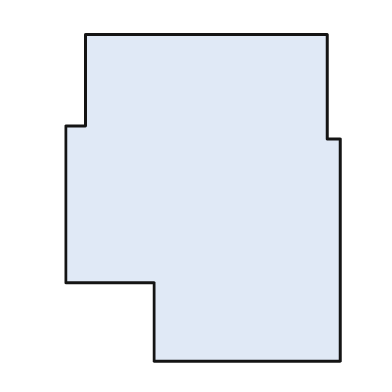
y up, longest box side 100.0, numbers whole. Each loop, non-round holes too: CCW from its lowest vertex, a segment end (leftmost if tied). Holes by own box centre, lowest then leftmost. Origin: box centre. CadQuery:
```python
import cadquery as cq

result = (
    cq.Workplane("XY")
    .moveTo(-15.0, -50.0)
    .lineTo(42.0, -50.0)
    .lineTo(42.0, 18.0)
    .lineTo(38.0, 18.0)
    .lineTo(38.0, 50.0)
    .lineTo(-36.0, 50.0)
    .lineTo(-36.0, 22.0)
    .lineTo(-42.0, 22.0)
    .lineTo(-42.0, -26.0)
    .lineTo(-15.0, -26.0)
    .close()
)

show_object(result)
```